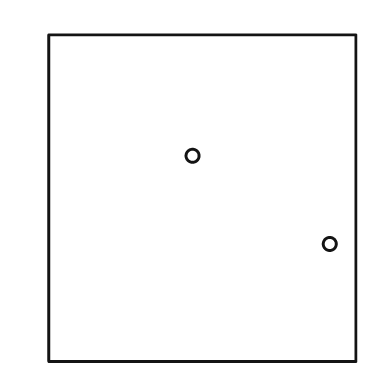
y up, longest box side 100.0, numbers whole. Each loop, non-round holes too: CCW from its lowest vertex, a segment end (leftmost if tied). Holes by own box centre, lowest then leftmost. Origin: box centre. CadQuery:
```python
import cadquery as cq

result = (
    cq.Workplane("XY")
    .moveTo(-47.0, -50.0)
    .lineTo(47.0, -50.0)
    .lineTo(47.0, 50.0)
    .lineTo(-47.0, 50.0)
    .close()
    .moveTo(39.0, -14.0)
    .circle(2.0)
    .moveTo(-3.0, 13.0)
    .circle(2.0)
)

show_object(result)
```